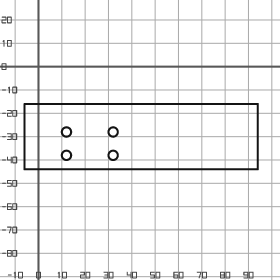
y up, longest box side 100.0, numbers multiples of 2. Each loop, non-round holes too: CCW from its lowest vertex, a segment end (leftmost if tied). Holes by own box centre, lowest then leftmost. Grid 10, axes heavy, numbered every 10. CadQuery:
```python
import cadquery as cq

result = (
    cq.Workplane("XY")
    .moveTo(-6.0, -44.0)
    .lineTo(94.0, -44.0)
    .lineTo(94.0, -16.0)
    .lineTo(-6.0, -16.0)
    .close()
    .moveTo(12.0, -38.0)
    .circle(2.0)
    .moveTo(32.0, -38.0)
    .circle(2.0)
    .moveTo(12.0, -28.0)
    .circle(2.0)
    .moveTo(32.0, -28.0)
    .circle(2.0)
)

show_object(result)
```